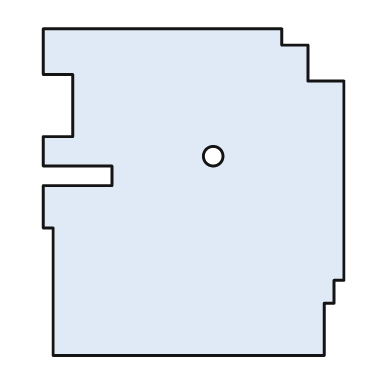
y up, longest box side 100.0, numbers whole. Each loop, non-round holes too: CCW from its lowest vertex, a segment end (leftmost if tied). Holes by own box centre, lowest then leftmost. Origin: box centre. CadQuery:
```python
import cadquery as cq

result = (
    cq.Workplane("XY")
    .moveTo(-43.0, -50.0)
    .lineTo(40.0, -50.0)
    .lineTo(40.0, -34.0)
    .lineTo(43.0, -34.0)
    .lineTo(43.0, -27.0)
    .lineTo(46.0, -27.0)
    .lineTo(46.0, 34.0)
    .lineTo(35.0, 34.0)
    .lineTo(35.0, 45.0)
    .lineTo(27.0, 45.0)
    .lineTo(27.0, 50.0)
    .lineTo(-46.0, 50.0)
    .lineTo(-46.0, 36.0)
    .lineTo(-37.0, 36.0)
    .lineTo(-37.0, 17.0)
    .lineTo(-46.0, 17.0)
    .lineTo(-46.0, 8.0)
    .lineTo(-25.0, 8.0)
    .lineTo(-25.0, 2.0)
    .lineTo(-46.0, 2.0)
    .lineTo(-46.0, -11.0)
    .lineTo(-43.0, -11.0)
    .close()
    .moveTo(6.0, 11.0)
    .circle(3.0)
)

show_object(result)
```